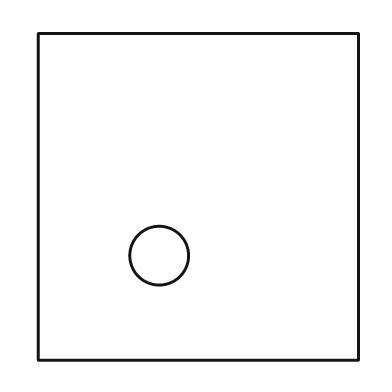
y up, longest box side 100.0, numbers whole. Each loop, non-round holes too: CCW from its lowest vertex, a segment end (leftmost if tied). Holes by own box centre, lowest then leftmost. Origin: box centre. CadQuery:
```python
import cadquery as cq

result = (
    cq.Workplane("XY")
    .moveTo(-49.0, -50.0)
    .lineTo(49.0, -50.0)
    .lineTo(49.0, 50.0)
    .lineTo(-49.0, 50.0)
    .close()
    .moveTo(-12.0, -18.0)
    .circle(9.0)
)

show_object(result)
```